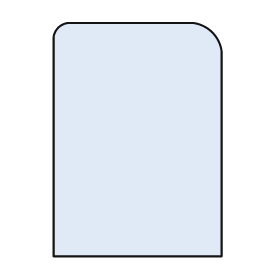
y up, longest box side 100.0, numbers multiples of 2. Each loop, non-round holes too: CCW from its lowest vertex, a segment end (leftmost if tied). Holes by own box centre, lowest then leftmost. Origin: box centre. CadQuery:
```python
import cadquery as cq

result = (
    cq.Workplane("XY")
    .moveTo(-36.0, -50.0)
    .lineTo(36.0, -50.0)
    .lineTo(36.0, 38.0)
    .threePointArc((32.0, 46.0), (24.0, 50.0))
    .lineTo(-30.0, 50.0)
    .threePointArc((-34.0, 48.0), (-36.0, 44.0))
    .close()
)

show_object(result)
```